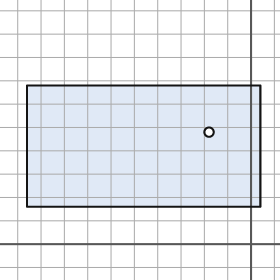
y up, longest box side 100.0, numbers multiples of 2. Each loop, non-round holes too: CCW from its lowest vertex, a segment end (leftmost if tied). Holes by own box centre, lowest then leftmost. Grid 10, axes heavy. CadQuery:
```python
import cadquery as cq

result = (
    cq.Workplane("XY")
    .moveTo(-96.0, 16.0)
    .lineTo(4.0, 16.0)
    .lineTo(4.0, 68.0)
    .lineTo(-96.0, 68.0)
    .close()
    .moveTo(-18.0, 48.0)
    .circle(2.0)
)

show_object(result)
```